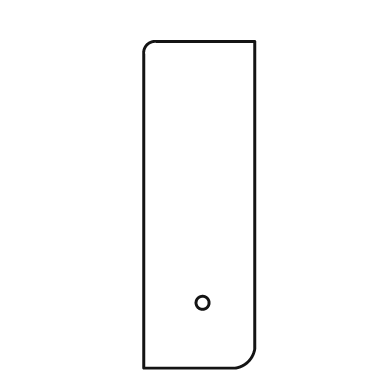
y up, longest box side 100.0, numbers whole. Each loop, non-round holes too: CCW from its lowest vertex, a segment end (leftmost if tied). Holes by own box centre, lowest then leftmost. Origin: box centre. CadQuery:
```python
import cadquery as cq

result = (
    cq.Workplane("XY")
    .moveTo(-17.0, -50.0)
    .lineTo(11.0, -50.0)
    .threePointArc((15.0, -48.0), (17.0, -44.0))
    .lineTo(17.0, 50.0)
    .lineTo(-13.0, 50.0)
    .threePointArc((-16.0, 49.0), (-17.0, 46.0))
    .close()
    .moveTo(1.0, -30.0)
    .circle(2.0)
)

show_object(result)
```